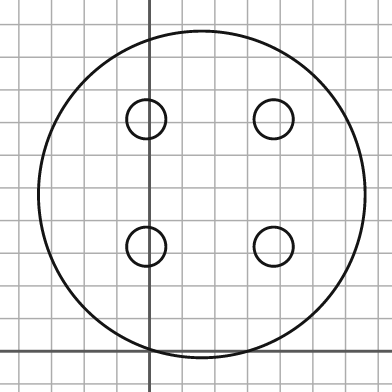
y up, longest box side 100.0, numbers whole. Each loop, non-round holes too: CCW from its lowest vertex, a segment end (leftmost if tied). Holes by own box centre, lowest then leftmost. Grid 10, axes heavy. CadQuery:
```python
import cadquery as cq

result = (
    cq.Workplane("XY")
    .moveTo(16.0, 48.0)
    .circle(50.0)
    .moveTo(-1.0, 32.0)
    .circle(6.0)
    .moveTo(38.0, 32.0)
    .circle(6.0)
    .moveTo(-1.0, 71.0)
    .circle(6.0)
    .moveTo(38.0, 71.0)
    .circle(6.0)
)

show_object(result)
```